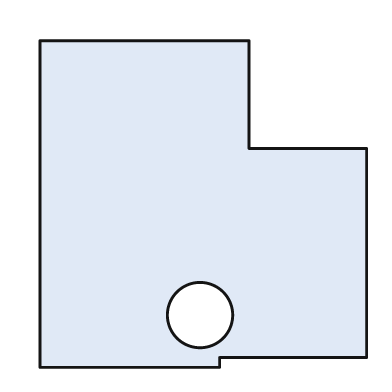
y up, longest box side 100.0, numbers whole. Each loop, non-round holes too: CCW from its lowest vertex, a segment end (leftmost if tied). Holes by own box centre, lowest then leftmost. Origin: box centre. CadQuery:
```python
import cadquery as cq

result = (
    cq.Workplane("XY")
    .moveTo(-50.0, -50.0)
    .lineTo(5.0, -50.0)
    .lineTo(5.0, -47.0)
    .lineTo(50.0, -47.0)
    .lineTo(50.0, 17.0)
    .lineTo(14.0, 17.0)
    .lineTo(14.0, 50.0)
    .lineTo(-50.0, 50.0)
    .close()
    .moveTo(-1.0, -34.0)
    .circle(10.0)
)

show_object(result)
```